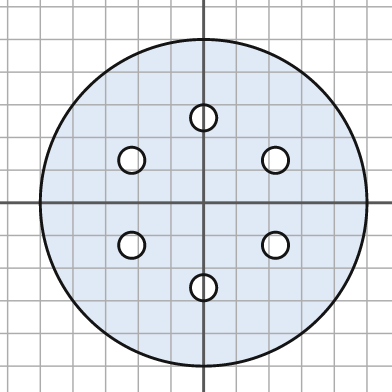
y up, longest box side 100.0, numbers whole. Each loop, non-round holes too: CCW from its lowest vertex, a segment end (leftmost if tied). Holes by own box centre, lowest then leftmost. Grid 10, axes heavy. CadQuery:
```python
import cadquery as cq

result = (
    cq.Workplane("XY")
    .moveTo(0.0, 0.0)
    .circle(50.0)
    .moveTo(0.0, -26.0)
    .circle(4.0)
    .moveTo(-22.0, -13.0)
    .circle(4.0)
    .moveTo(22.0, -13.0)
    .circle(4.0)
    .moveTo(-22.0, 13.0)
    .circle(4.0)
    .moveTo(22.0, 13.0)
    .circle(4.0)
    .moveTo(0.0, 26.0)
    .circle(4.0)
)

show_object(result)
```